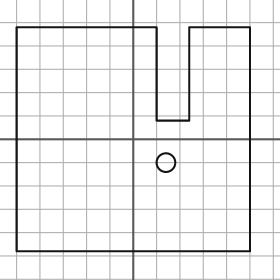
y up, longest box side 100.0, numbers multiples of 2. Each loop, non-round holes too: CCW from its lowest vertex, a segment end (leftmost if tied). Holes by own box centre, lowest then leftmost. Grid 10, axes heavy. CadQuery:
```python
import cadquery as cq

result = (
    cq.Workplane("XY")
    .moveTo(-50.0, -48.0)
    .lineTo(50.0, -48.0)
    .lineTo(50.0, 48.0)
    .lineTo(24.0, 48.0)
    .lineTo(24.0, 8.0)
    .lineTo(10.0, 8.0)
    .lineTo(10.0, 48.0)
    .lineTo(-50.0, 48.0)
    .close()
    .moveTo(14.0, -10.0)
    .circle(4.0)
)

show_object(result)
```